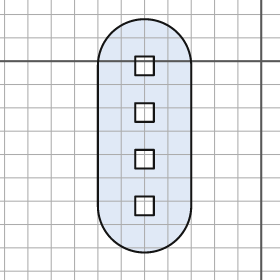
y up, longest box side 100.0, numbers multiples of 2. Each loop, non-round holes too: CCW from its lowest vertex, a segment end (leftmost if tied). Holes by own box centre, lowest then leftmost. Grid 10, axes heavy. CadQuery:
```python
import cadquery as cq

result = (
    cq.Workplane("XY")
    .moveTo(-70.0, -62.0)
    .threePointArc((-50.0, -82.0), (-30.0, -62.0))
    .lineTo(-30.0, -2.0)
    .threePointArc((-50.0, 18.0), (-70.0, -2.0))
    .close()
    .moveTo(-54.0, -66.0)
    .lineTo(-46.0, -66.0)
    .lineTo(-46.0, -58.0)
    .lineTo(-54.0, -58.0)
    .close()
    .moveTo(-54.0, -46.0)
    .lineTo(-46.0, -46.0)
    .lineTo(-46.0, -38.0)
    .lineTo(-54.0, -38.0)
    .close()
    .moveTo(-54.0, -26.0)
    .lineTo(-46.0, -26.0)
    .lineTo(-46.0, -18.0)
    .lineTo(-54.0, -18.0)
    .close()
    .moveTo(-54.0, -6.0)
    .lineTo(-46.0, -6.0)
    .lineTo(-46.0, 2.0)
    .lineTo(-54.0, 2.0)
    .close()
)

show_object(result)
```